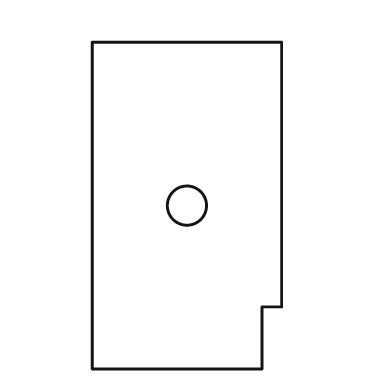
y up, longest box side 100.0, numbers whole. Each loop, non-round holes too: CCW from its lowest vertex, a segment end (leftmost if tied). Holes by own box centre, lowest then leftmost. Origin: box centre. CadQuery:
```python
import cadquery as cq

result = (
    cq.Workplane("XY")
    .moveTo(-29.0, -50.0)
    .lineTo(23.0, -50.0)
    .lineTo(23.0, -31.0)
    .lineTo(29.0, -31.0)
    .lineTo(29.0, 50.0)
    .lineTo(-29.0, 50.0)
    .close()
    .moveTo(0.0, 0.0)
    .circle(6.0)
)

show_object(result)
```